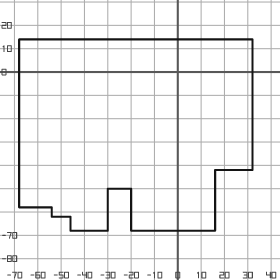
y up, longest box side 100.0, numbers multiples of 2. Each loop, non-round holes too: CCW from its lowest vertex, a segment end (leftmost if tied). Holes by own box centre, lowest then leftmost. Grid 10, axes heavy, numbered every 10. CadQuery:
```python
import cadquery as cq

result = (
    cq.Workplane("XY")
    .moveTo(-46.0, -68.0)
    .lineTo(-30.0, -68.0)
    .lineTo(-30.0, -50.0)
    .lineTo(-20.0, -50.0)
    .lineTo(-20.0, -68.0)
    .lineTo(16.0, -68.0)
    .lineTo(16.0, -42.0)
    .lineTo(32.0, -42.0)
    .lineTo(32.0, 14.0)
    .lineTo(-68.0, 14.0)
    .lineTo(-68.0, -58.0)
    .lineTo(-54.0, -58.0)
    .lineTo(-54.0, -62.0)
    .lineTo(-46.0, -62.0)
    .close()
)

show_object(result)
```